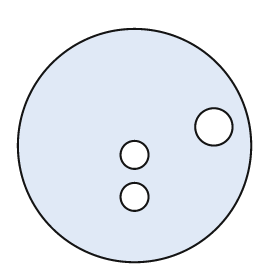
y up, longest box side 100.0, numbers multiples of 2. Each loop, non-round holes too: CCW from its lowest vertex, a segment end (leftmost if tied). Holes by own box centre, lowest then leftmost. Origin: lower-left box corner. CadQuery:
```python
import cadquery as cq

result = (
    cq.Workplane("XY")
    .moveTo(50.0, 50.0)
    .circle(50.0)
    .moveTo(50.0, 28.0)
    .circle(6.0)
    .moveTo(50.0, 46.0)
    .circle(6.0)
    .moveTo(84.0, 58.0)
    .circle(8.0)
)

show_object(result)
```